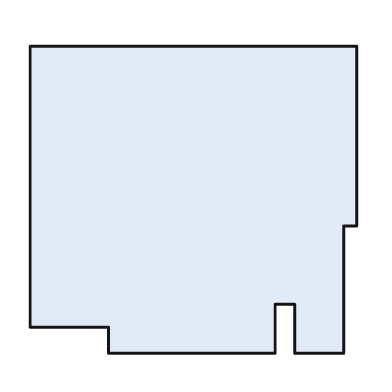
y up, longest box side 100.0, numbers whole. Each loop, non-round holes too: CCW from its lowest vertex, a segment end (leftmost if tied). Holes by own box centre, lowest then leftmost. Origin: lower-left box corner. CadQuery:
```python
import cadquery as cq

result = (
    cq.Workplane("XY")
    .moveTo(24.0, 0.0)
    .lineTo(75.0, 0.0)
    .lineTo(75.0, 15.0)
    .lineTo(81.0, 15.0)
    .lineTo(81.0, 0.0)
    .lineTo(96.0, 0.0)
    .lineTo(96.0, 39.0)
    .lineTo(100.0, 39.0)
    .lineTo(100.0, 94.0)
    .lineTo(0.0, 94.0)
    .lineTo(0.0, 8.0)
    .lineTo(24.0, 8.0)
    .close()
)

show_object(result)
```